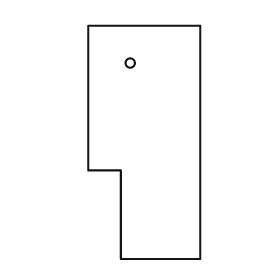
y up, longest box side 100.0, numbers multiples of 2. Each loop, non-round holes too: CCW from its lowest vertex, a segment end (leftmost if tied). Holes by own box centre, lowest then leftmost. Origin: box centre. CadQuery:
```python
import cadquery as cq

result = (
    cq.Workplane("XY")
    .moveTo(-10.0, -50.0)
    .lineTo(24.0, -50.0)
    .lineTo(24.0, 50.0)
    .lineTo(-24.0, 50.0)
    .lineTo(-24.0, -12.0)
    .lineTo(-10.0, -12.0)
    .close()
    .moveTo(-6.0, 34.0)
    .circle(2.0)
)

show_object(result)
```